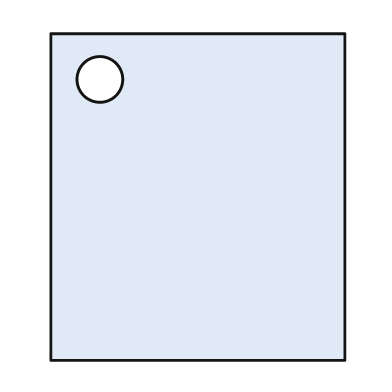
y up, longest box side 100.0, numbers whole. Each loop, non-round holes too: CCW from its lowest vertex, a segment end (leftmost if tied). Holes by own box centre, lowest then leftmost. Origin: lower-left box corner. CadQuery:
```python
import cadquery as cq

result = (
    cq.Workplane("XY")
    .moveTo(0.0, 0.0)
    .lineTo(90.0, 0.0)
    .lineTo(90.0, 100.0)
    .lineTo(0.0, 100.0)
    .close()
    .moveTo(15.0, 86.0)
    .circle(7.0)
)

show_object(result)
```